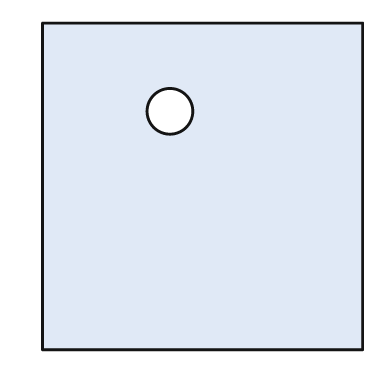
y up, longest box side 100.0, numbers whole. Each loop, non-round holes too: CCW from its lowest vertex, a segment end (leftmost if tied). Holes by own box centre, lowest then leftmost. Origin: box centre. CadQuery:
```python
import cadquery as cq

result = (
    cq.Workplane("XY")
    .moveTo(-49.0, -50.0)
    .lineTo(49.0, -50.0)
    .lineTo(49.0, 50.0)
    .lineTo(-49.0, 50.0)
    .close()
    .moveTo(-10.0, 23.0)
    .circle(7.0)
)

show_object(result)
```